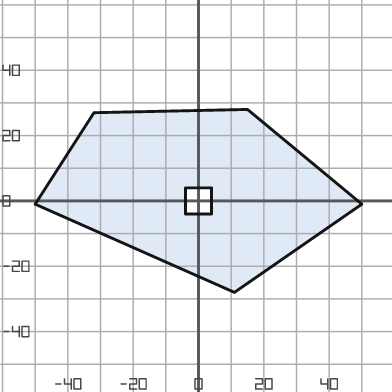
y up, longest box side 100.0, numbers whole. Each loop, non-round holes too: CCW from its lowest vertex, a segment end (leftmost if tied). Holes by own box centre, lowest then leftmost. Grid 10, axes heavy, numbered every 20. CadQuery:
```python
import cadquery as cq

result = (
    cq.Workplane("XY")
    .moveTo(11.0, -28.0)
    .lineTo(50.0, -1.0)
    .lineTo(15.0, 28.0)
    .lineTo(-32.0, 27.0)
    .lineTo(-50.0, -1.0)
    .close()
    .moveTo(-4.0, -4.0)
    .lineTo(4.0, -4.0)
    .lineTo(4.0, 4.0)
    .lineTo(-4.0, 4.0)
    .close()
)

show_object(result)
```